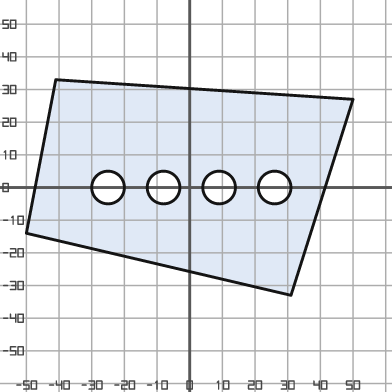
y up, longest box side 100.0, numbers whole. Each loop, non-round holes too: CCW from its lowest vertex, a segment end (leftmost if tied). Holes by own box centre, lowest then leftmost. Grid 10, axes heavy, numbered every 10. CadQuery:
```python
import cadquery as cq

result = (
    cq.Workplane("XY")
    .moveTo(31.0, -33.0)
    .lineTo(50.0, 27.0)
    .lineTo(-41.0, 33.0)
    .lineTo(-50.0, -14.0)
    .close()
    .moveTo(-25.0, 0.0)
    .circle(5.0)
    .moveTo(-8.0, 0.0)
    .circle(5.0)
    .moveTo(9.0, 0.0)
    .circle(5.0)
    .moveTo(26.0, 0.0)
    .circle(5.0)
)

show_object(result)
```